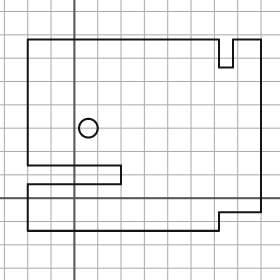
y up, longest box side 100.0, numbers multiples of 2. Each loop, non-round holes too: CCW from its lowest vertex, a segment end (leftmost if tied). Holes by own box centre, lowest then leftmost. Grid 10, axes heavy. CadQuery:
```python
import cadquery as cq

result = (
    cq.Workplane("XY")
    .moveTo(-20.0, -14.0)
    .lineTo(62.0, -14.0)
    .lineTo(62.0, -6.0)
    .lineTo(80.0, -6.0)
    .lineTo(80.0, 68.0)
    .lineTo(68.0, 68.0)
    .lineTo(68.0, 56.0)
    .lineTo(62.0, 56.0)
    .lineTo(62.0, 68.0)
    .lineTo(-20.0, 68.0)
    .lineTo(-20.0, 14.0)
    .lineTo(20.0, 14.0)
    .lineTo(20.0, 6.0)
    .lineTo(-20.0, 6.0)
    .close()
    .moveTo(6.0, 30.0)
    .circle(4.0)
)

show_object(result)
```